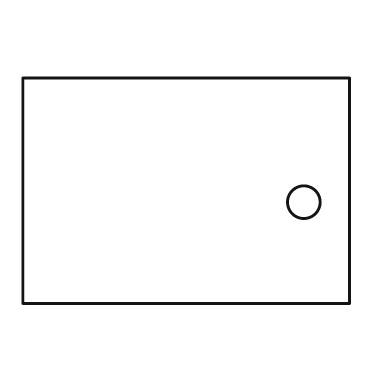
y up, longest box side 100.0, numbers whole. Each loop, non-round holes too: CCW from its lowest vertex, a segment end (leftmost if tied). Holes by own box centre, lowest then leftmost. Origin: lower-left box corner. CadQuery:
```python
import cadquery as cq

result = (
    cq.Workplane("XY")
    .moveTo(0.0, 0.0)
    .lineTo(100.0, 0.0)
    .lineTo(100.0, 69.0)
    .lineTo(0.0, 69.0)
    .close()
    .moveTo(86.0, 31.0)
    .circle(5.0)
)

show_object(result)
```